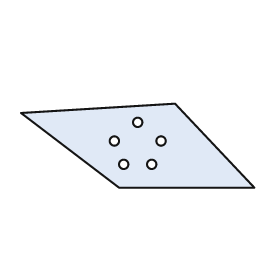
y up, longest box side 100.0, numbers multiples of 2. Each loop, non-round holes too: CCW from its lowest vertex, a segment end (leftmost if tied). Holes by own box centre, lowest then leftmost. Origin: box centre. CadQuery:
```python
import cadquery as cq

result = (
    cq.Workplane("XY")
    .moveTo(-8.0, -18.0)
    .lineTo(50.0, -18.0)
    .lineTo(16.0, 18.0)
    .lineTo(-50.0, 14.0)
    .close()
    .moveTo(-6.0, -8.0)
    .circle(2.0)
    .moveTo(6.0, -8.0)
    .circle(2.0)
    .moveTo(-10.0, 2.0)
    .circle(2.0)
    .moveTo(10.0, 2.0)
    .circle(2.0)
    .moveTo(0.0, 10.0)
    .circle(2.0)
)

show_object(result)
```